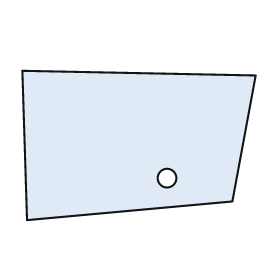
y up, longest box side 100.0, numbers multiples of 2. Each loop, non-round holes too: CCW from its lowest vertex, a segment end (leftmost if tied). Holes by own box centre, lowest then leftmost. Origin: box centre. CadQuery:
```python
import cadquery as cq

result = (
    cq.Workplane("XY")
    .moveTo(-48.0, -32.0)
    .lineTo(40.0, -24.0)
    .lineTo(50.0, 30.0)
    .lineTo(-50.0, 32.0)
    .close()
    .moveTo(12.0, -14.0)
    .circle(4.0)
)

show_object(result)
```